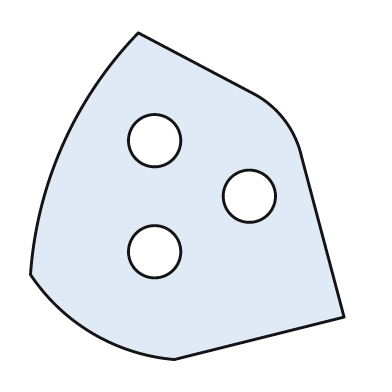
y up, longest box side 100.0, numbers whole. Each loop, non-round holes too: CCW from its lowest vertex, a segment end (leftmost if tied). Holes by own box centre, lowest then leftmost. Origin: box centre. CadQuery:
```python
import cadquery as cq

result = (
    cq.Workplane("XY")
    .moveTo(-4.0, -50.0)
    .lineTo(48.0, -37.0)
    .lineTo(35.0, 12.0)
    .threePointArc((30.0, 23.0), (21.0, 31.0))
    .lineTo(-15.0, 50.0)
    .threePointArc((-38.0, 16.0), (-48.0, -24.0))
    .threePointArc((-29.0, -42.0), (-4.0, -50.0))
    .close()
    .moveTo(-10.0, -17.0)
    .circle(8.0)
    .moveTo(19.0, 0.0)
    .circle(8.0)
    .moveTo(-10.0, 17.0)
    .circle(8.0)
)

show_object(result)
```